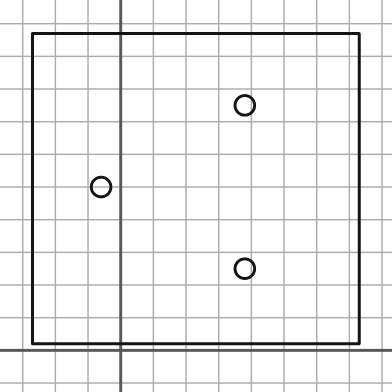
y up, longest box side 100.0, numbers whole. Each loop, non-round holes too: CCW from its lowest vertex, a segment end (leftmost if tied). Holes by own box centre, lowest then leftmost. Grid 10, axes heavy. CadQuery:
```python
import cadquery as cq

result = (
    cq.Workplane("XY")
    .moveTo(-27.0, 2.0)
    .lineTo(73.0, 2.0)
    .lineTo(73.0, 97.0)
    .lineTo(-27.0, 97.0)
    .close()
    .moveTo(38.0, 25.0)
    .circle(3.0)
    .moveTo(-6.0, 50.0)
    .circle(3.0)
    .moveTo(38.0, 75.0)
    .circle(3.0)
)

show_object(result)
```